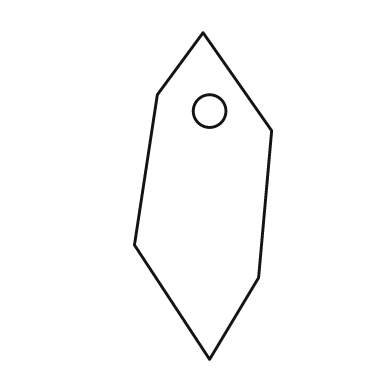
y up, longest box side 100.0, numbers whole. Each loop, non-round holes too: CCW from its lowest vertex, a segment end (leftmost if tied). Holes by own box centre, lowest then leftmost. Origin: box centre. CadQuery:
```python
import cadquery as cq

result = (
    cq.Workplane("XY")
    .moveTo(2.0, -50.0)
    .lineTo(17.0, -25.0)
    .lineTo(21.0, 20.0)
    .lineTo(0.0, 50.0)
    .lineTo(-14.0, 31.0)
    .lineTo(-21.0, -15.0)
    .close()
    .moveTo(2.0, 26.0)
    .circle(5.0)
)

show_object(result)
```